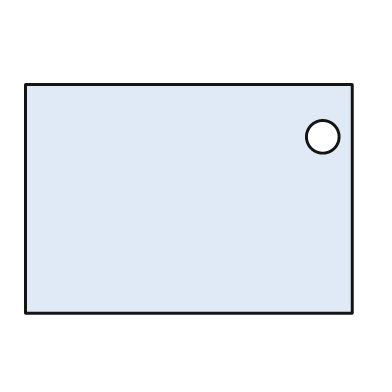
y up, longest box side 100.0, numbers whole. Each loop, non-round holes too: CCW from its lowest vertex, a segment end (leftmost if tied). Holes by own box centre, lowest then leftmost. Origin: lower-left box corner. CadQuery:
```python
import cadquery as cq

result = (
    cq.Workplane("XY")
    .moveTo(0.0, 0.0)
    .lineTo(100.0, 0.0)
    .lineTo(100.0, 70.0)
    .lineTo(0.0, 70.0)
    .close()
    .moveTo(91.0, 54.0)
    .circle(5.0)
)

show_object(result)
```